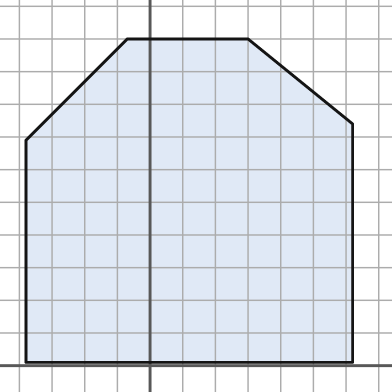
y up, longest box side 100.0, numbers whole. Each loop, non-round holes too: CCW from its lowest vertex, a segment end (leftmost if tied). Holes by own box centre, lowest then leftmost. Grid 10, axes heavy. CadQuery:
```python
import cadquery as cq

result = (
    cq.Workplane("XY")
    .moveTo(-38.0, 1.0)
    .lineTo(62.0, 1.0)
    .lineTo(62.0, 74.0)
    .lineTo(30.0, 100.0)
    .lineTo(-7.0, 100.0)
    .lineTo(-38.0, 69.0)
    .close()
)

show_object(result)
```